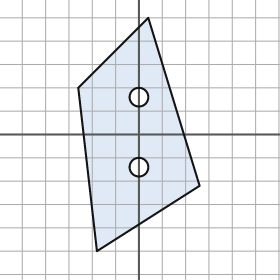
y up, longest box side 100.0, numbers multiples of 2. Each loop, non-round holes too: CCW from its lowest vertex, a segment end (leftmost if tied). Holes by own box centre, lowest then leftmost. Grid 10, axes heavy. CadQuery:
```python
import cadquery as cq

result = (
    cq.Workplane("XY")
    .moveTo(-18.0, -50.0)
    .lineTo(26.0, -22.0)
    .lineTo(4.0, 50.0)
    .lineTo(-26.0, 20.0)
    .close()
    .moveTo(0.0, -14.0)
    .circle(4.0)
    .moveTo(0.0, 16.0)
    .circle(4.0)
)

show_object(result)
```